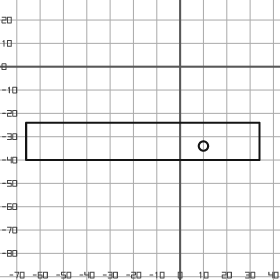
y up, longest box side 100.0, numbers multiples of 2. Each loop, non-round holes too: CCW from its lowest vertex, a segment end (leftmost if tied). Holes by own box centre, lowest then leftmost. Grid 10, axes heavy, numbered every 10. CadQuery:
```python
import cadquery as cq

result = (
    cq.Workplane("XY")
    .moveTo(-66.0, -40.0)
    .lineTo(34.0, -40.0)
    .lineTo(34.0, -24.0)
    .lineTo(-66.0, -24.0)
    .close()
    .moveTo(10.0, -34.0)
    .circle(2.0)
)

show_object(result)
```